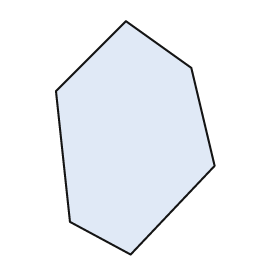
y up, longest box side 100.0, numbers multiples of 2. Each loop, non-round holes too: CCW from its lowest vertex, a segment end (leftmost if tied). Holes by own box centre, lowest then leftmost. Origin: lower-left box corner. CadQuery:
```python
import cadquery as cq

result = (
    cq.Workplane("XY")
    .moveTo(32.0, 0.0)
    .lineTo(68.0, 38.0)
    .lineTo(58.0, 80.0)
    .lineTo(30.0, 100.0)
    .lineTo(0.0, 70.0)
    .lineTo(6.0, 14.0)
    .close()
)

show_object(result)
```